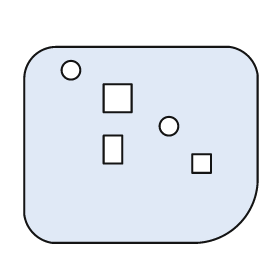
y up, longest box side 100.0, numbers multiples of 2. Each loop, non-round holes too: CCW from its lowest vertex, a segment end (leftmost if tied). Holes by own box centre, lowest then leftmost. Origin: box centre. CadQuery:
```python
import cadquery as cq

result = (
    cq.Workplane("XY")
    .moveTo(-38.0, -42.0)
    .lineTo(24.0, -42.0)
    .threePointArc((42.0, -34.0), (50.0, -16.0))
    .lineTo(50.0, 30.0)
    .threePointArc((46.0, 38.0), (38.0, 42.0))
    .lineTo(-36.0, 42.0)
    .threePointArc((-46.0, 38.0), (-50.0, 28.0))
    .lineTo(-50.0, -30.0)
    .threePointArc((-46.0, -38.0), (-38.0, -42.0))
    .close()
    .moveTo(22.0, -12.0)
    .lineTo(30.0, -12.0)
    .lineTo(30.0, -4.0)
    .lineTo(22.0, -4.0)
    .close()
    .moveTo(-16.0, -8.0)
    .lineTo(-8.0, -8.0)
    .lineTo(-8.0, 4.0)
    .lineTo(-16.0, 4.0)
    .close()
    .moveTo(12.0, 8.0)
    .circle(4.0)
    .moveTo(-16.0, 14.0)
    .lineTo(-4.0, 14.0)
    .lineTo(-4.0, 26.0)
    .lineTo(-16.0, 26.0)
    .close()
    .moveTo(-30.0, 32.0)
    .circle(4.0)
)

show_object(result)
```